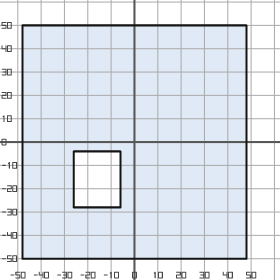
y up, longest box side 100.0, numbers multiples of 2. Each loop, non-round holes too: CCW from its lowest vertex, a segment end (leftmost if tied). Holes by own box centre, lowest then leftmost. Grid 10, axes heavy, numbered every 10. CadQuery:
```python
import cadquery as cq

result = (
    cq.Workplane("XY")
    .moveTo(-48.0, -50.0)
    .lineTo(48.0, -50.0)
    .lineTo(48.0, 50.0)
    .lineTo(-48.0, 50.0)
    .close()
    .moveTo(-26.0, -28.0)
    .lineTo(-6.0, -28.0)
    .lineTo(-6.0, -4.0)
    .lineTo(-26.0, -4.0)
    .close()
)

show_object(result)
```